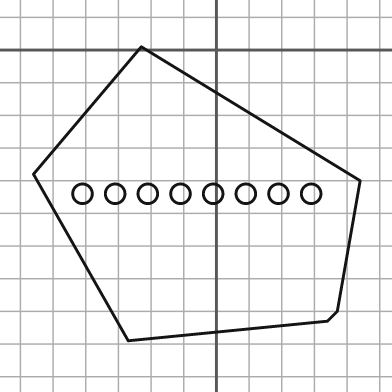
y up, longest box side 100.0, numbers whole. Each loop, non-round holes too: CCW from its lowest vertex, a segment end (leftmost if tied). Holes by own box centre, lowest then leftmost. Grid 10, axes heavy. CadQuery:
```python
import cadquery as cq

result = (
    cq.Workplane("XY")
    .moveTo(-27.0, -89.0)
    .lineTo(34.0, -83.0)
    .lineTo(37.0, -80.0)
    .lineTo(44.0, -40.0)
    .lineTo(-23.0, 1.0)
    .lineTo(-56.0, -38.0)
    .close()
    .moveTo(-41.0, -44.0)
    .circle(3.0)
    .moveTo(-31.0, -44.0)
    .circle(3.0)
    .moveTo(-21.0, -44.0)
    .circle(3.0)
    .moveTo(-11.0, -44.0)
    .circle(3.0)
    .moveTo(-1.0, -44.0)
    .circle(3.0)
    .moveTo(9.0, -44.0)
    .circle(3.0)
    .moveTo(19.0, -44.0)
    .circle(3.0)
    .moveTo(29.0, -44.0)
    .circle(3.0)
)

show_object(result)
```